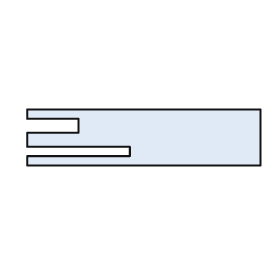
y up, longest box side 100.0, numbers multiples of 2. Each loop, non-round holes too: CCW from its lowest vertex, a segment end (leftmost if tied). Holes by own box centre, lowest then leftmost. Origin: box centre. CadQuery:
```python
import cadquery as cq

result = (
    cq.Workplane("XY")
    .moveTo(-50.0, -12.0)
    .lineTo(50.0, -12.0)
    .lineTo(50.0, 12.0)
    .lineTo(-50.0, 12.0)
    .lineTo(-50.0, 8.0)
    .lineTo(-28.0, 8.0)
    .lineTo(-28.0, 2.0)
    .lineTo(-50.0, 2.0)
    .lineTo(-50.0, -4.0)
    .lineTo(-6.0, -4.0)
    .lineTo(-6.0, -8.0)
    .lineTo(-50.0, -8.0)
    .close()
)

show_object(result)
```